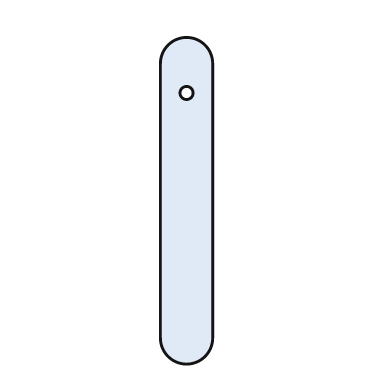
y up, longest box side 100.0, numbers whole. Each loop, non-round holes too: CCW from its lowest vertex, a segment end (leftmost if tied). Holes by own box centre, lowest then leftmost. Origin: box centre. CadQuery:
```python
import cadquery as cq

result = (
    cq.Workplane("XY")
    .moveTo(-8.0, -42.0)
    .threePointArc((0.0, -50.0), (8.0, -42.0))
    .lineTo(8.0, 42.0)
    .threePointArc((0.0, 50.0), (-8.0, 42.0))
    .close()
    .moveTo(0.0, 33.0)
    .circle(2.0)
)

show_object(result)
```